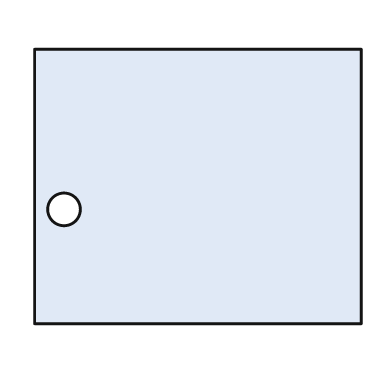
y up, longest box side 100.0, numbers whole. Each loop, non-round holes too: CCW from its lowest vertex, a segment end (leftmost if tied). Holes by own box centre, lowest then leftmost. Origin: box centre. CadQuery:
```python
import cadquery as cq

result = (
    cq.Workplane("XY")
    .moveTo(-50.0, -42.0)
    .lineTo(50.0, -42.0)
    .lineTo(50.0, 42.0)
    .lineTo(-50.0, 42.0)
    .close()
    .moveTo(-41.0, -7.0)
    .circle(5.0)
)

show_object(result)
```